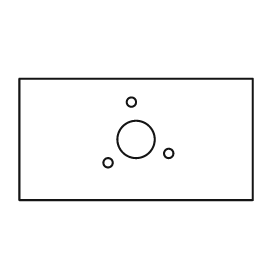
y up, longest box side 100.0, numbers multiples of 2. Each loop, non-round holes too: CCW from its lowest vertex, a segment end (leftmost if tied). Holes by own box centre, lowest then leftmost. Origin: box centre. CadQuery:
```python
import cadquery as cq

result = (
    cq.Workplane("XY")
    .moveTo(-50.0, -26.0)
    .lineTo(50.0, -26.0)
    .lineTo(50.0, 26.0)
    .lineTo(-50.0, 26.0)
    .close()
    .moveTo(-12.0, -10.0)
    .circle(2.0)
    .moveTo(14.0, -6.0)
    .circle(2.0)
    .moveTo(0.0, 0.0)
    .circle(8.0)
    .moveTo(-2.0, 16.0)
    .circle(2.0)
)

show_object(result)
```